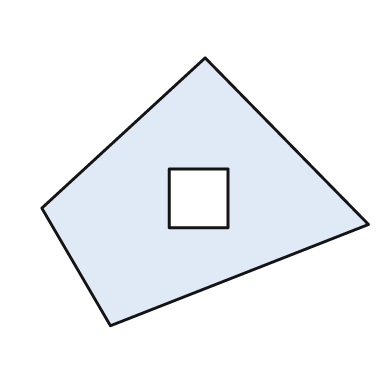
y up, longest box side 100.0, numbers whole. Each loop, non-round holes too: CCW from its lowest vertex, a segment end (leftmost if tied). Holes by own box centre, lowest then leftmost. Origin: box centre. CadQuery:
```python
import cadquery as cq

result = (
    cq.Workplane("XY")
    .moveTo(-29.0, -41.0)
    .lineTo(50.0, -10.0)
    .lineTo(0.0, 41.0)
    .lineTo(-50.0, -5.0)
    .close()
    .moveTo(-11.0, -11.0)
    .lineTo(7.0, -11.0)
    .lineTo(7.0, 7.0)
    .lineTo(-11.0, 7.0)
    .close()
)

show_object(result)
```